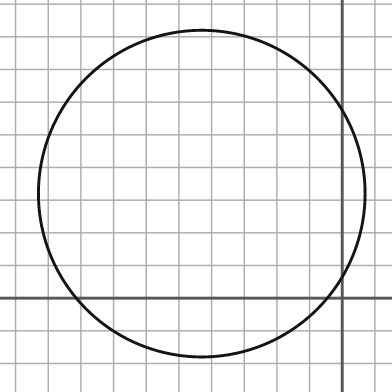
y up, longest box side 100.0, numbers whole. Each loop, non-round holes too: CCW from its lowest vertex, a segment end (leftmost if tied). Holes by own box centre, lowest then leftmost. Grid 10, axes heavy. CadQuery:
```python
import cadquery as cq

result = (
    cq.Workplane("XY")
    .moveTo(-43.0, 32.0)
    .circle(50.0)
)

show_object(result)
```